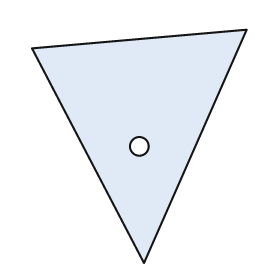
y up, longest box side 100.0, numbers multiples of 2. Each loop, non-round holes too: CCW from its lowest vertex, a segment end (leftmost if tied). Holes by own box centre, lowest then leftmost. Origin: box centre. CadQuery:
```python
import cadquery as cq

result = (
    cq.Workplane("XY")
    .moveTo(2.0, -50.0)
    .lineTo(46.0, 50.0)
    .lineTo(-46.0, 42.0)
    .close()
    .moveTo(0.0, 0.0)
    .circle(4.0)
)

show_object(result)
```